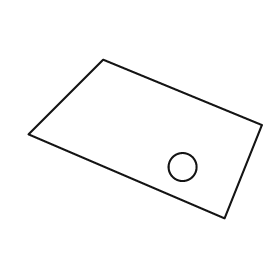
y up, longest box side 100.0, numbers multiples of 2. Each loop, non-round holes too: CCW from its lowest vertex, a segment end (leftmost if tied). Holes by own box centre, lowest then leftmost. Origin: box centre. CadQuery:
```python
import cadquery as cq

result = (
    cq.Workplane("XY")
    .moveTo(34.0, -34.0)
    .lineTo(50.0, 6.0)
    .lineTo(-18.0, 34.0)
    .lineTo(-50.0, 2.0)
    .close()
    .moveTo(16.0, -12.0)
    .circle(6.0)
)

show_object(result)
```